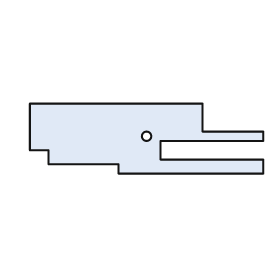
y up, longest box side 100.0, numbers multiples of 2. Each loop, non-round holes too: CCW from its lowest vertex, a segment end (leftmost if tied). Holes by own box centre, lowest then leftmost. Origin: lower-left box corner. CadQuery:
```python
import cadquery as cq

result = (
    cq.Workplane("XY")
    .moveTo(38.0, 0.0)
    .lineTo(100.0, 0.0)
    .lineTo(100.0, 6.0)
    .lineTo(56.0, 6.0)
    .lineTo(56.0, 14.0)
    .lineTo(100.0, 14.0)
    .lineTo(100.0, 18.0)
    .lineTo(74.0, 18.0)
    .lineTo(74.0, 30.0)
    .lineTo(0.0, 30.0)
    .lineTo(0.0, 10.0)
    .lineTo(8.0, 10.0)
    .lineTo(8.0, 4.0)
    .lineTo(38.0, 4.0)
    .close()
    .moveTo(50.0, 16.0)
    .circle(2.0)
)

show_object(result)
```